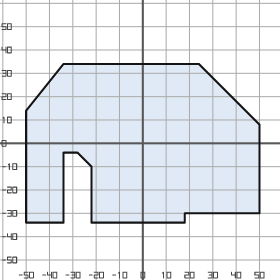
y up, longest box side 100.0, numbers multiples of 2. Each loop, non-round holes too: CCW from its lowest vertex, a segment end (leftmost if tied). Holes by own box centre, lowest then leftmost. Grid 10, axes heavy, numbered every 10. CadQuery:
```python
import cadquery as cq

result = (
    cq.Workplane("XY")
    .moveTo(-50.0, -34.0)
    .lineTo(-34.0, -34.0)
    .lineTo(-34.0, -4.0)
    .lineTo(-28.0, -4.0)
    .lineTo(-22.0, -10.0)
    .lineTo(-22.0, -34.0)
    .lineTo(18.0, -34.0)
    .lineTo(18.0, -30.0)
    .lineTo(50.0, -30.0)
    .lineTo(50.0, 8.0)
    .lineTo(24.0, 34.0)
    .lineTo(-34.0, 34.0)
    .lineTo(-50.0, 14.0)
    .close()
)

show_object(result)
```